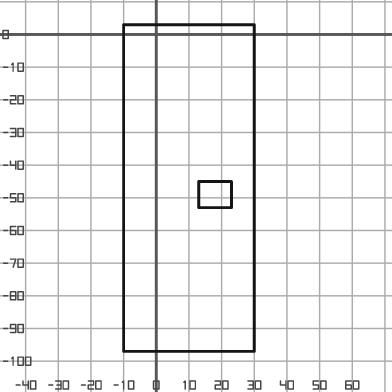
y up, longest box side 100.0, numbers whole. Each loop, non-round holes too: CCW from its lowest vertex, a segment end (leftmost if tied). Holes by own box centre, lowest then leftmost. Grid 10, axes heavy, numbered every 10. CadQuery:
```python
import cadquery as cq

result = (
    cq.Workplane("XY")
    .moveTo(-10.0, -97.0)
    .lineTo(30.0, -97.0)
    .lineTo(30.0, 3.0)
    .lineTo(-10.0, 3.0)
    .close()
    .moveTo(13.0, -53.0)
    .lineTo(23.0, -53.0)
    .lineTo(23.0, -45.0)
    .lineTo(13.0, -45.0)
    .close()
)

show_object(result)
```